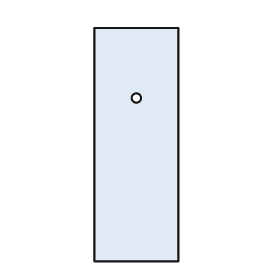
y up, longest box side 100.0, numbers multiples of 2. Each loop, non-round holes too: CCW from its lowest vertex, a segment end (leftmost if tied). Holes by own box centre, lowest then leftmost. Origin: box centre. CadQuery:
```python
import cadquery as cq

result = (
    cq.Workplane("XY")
    .moveTo(-18.0, -50.0)
    .lineTo(18.0, -50.0)
    .lineTo(18.0, 50.0)
    .lineTo(-18.0, 50.0)
    .close()
    .moveTo(0.0, 20.0)
    .circle(2.0)
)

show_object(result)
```